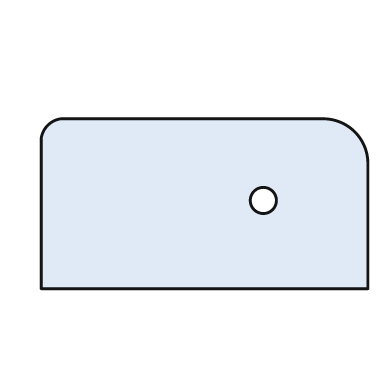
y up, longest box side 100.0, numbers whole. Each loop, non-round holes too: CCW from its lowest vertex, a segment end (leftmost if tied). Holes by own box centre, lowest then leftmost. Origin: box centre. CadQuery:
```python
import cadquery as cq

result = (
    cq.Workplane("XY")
    .moveTo(-50.0, -26.0)
    .lineTo(50.0, -26.0)
    .lineTo(50.0, 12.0)
    .threePointArc((46.0, 22.0), (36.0, 26.0))
    .lineTo(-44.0, 26.0)
    .threePointArc((-48.0, 24.0), (-50.0, 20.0))
    .close()
    .moveTo(18.0, 1.0)
    .circle(4.0)
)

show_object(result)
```